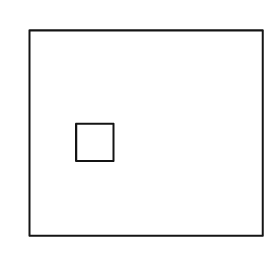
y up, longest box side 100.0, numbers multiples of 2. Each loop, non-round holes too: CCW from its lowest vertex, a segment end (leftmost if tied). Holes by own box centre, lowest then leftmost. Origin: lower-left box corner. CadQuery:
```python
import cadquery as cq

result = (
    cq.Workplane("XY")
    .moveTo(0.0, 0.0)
    .lineTo(100.0, 0.0)
    .lineTo(100.0, 88.0)
    .lineTo(0.0, 88.0)
    .close()
    .moveTo(20.0, 32.0)
    .lineTo(36.0, 32.0)
    .lineTo(36.0, 48.0)
    .lineTo(20.0, 48.0)
    .close()
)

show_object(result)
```